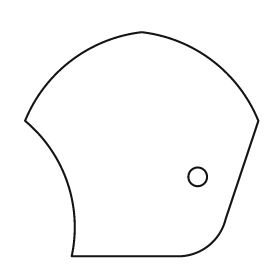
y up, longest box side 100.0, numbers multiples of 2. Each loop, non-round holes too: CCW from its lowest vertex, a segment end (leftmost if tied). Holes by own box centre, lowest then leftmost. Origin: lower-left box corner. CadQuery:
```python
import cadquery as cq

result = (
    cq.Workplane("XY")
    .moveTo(20.0, 0.0)
    .lineTo(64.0, 0.0)
    .threePointArc((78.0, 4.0), (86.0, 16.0))
    .lineTo(100.0, 58.0)
    .threePointArc((80.0, 84.0), (50.0, 96.0))
    .threePointArc((20.0, 84.0), (0.0, 58.0))
    .threePointArc((18.0, 32.0), (20.0, 0.0))
    .close()
    .moveTo(74.0, 34.0)
    .circle(4.0)
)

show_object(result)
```